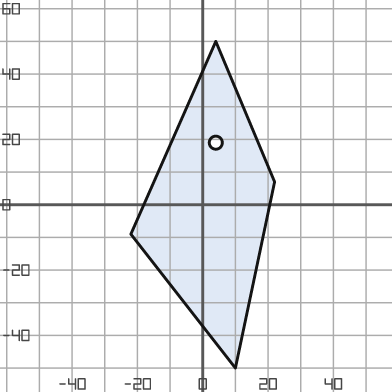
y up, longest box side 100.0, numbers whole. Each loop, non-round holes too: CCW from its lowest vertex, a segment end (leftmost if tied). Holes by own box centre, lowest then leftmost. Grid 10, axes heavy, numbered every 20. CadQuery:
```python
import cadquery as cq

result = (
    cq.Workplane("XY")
    .moveTo(10.0, -50.0)
    .lineTo(22.0, 7.0)
    .lineTo(4.0, 50.0)
    .lineTo(-22.0, -9.0)
    .close()
    .moveTo(4.0, 19.0)
    .circle(2.0)
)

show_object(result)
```